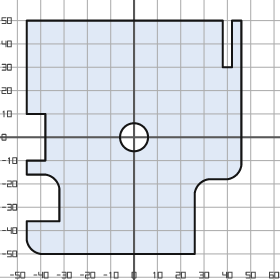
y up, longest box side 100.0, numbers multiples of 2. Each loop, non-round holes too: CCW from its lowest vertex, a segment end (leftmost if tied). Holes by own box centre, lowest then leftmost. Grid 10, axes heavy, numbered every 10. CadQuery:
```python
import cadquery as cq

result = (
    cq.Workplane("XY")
    .moveTo(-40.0, -50.0)
    .lineTo(26.0, -50.0)
    .lineTo(26.0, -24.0)
    .threePointArc((28.0, -20.0), (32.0, -18.0))
    .lineTo(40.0, -18.0)
    .threePointArc((44.0, -16.0), (46.0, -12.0))
    .lineTo(46.0, 50.0)
    .lineTo(42.0, 50.0)
    .lineTo(42.0, 30.0)
    .lineTo(38.0, 30.0)
    .lineTo(38.0, 50.0)
    .lineTo(-46.0, 50.0)
    .lineTo(-46.0, 10.0)
    .lineTo(-38.0, 10.0)
    .lineTo(-38.0, -10.0)
    .lineTo(-46.0, -10.0)
    .lineTo(-46.0, -16.0)
    .lineTo(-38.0, -16.0)
    .threePointArc((-34.0, -18.0), (-32.0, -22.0))
    .lineTo(-32.0, -36.0)
    .lineTo(-46.0, -36.0)
    .lineTo(-46.0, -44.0)
    .threePointArc((-44.0, -48.0), (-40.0, -50.0))
    .close()
    .moveTo(0.0, 0.0)
    .circle(6.0)
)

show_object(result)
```